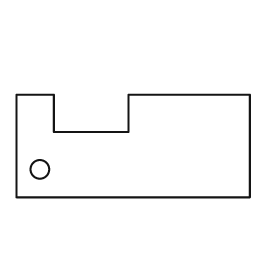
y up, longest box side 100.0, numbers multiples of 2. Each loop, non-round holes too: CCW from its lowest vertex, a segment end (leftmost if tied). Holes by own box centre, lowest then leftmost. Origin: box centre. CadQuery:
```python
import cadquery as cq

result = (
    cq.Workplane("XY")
    .moveTo(-50.0, -22.0)
    .lineTo(50.0, -22.0)
    .lineTo(50.0, 22.0)
    .lineTo(-2.0, 22.0)
    .lineTo(-2.0, 6.0)
    .lineTo(-34.0, 6.0)
    .lineTo(-34.0, 22.0)
    .lineTo(-50.0, 22.0)
    .close()
    .moveTo(-40.0, -10.0)
    .circle(4.0)
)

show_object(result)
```